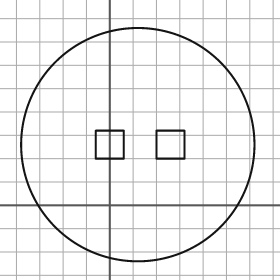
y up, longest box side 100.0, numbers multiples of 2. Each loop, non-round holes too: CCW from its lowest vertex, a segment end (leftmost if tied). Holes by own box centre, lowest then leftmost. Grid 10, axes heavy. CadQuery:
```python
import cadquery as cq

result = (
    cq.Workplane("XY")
    .moveTo(12.0, 26.0)
    .circle(50.0)
    .moveTo(-6.0, 20.0)
    .lineTo(6.0, 20.0)
    .lineTo(6.0, 32.0)
    .lineTo(-6.0, 32.0)
    .close()
    .moveTo(20.0, 20.0)
    .lineTo(32.0, 20.0)
    .lineTo(32.0, 32.0)
    .lineTo(20.0, 32.0)
    .close()
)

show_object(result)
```